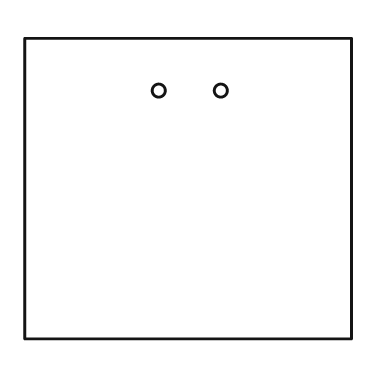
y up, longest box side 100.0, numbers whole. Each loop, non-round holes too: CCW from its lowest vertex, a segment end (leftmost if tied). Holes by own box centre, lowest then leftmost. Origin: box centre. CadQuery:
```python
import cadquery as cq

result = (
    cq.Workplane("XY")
    .moveTo(-50.0, -46.0)
    .lineTo(50.0, -46.0)
    .lineTo(50.0, 46.0)
    .lineTo(-50.0, 46.0)
    .close()
    .moveTo(-9.0, 30.0)
    .circle(2.0)
    .moveTo(10.0, 30.0)
    .circle(2.0)
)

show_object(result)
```